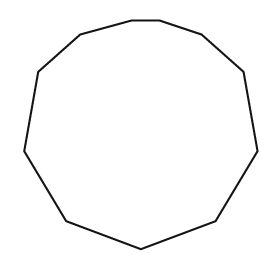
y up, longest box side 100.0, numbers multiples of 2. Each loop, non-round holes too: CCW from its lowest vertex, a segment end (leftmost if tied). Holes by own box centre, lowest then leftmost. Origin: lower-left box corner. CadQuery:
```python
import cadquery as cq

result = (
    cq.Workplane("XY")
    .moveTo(50.0, 0.0)
    .lineTo(82.0, 12.0)
    .lineTo(100.0, 42.0)
    .lineTo(94.0, 76.0)
    .lineTo(76.0, 92.0)
    .lineTo(58.0, 98.0)
    .lineTo(46.0, 98.0)
    .lineTo(24.0, 92.0)
    .lineTo(6.0, 76.0)
    .lineTo(0.0, 42.0)
    .lineTo(18.0, 12.0)
    .close()
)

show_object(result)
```